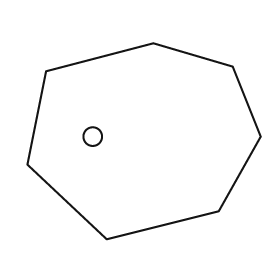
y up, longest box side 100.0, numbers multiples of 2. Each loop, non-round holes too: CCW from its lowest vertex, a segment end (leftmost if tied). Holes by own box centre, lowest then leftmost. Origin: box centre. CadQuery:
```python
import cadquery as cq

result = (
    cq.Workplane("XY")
    .moveTo(-16.0, -42.0)
    .lineTo(32.0, -30.0)
    .lineTo(50.0, 2.0)
    .lineTo(38.0, 32.0)
    .lineTo(4.0, 42.0)
    .lineTo(-42.0, 30.0)
    .lineTo(-50.0, -10.0)
    .close()
    .moveTo(-22.0, 2.0)
    .circle(4.0)
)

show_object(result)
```